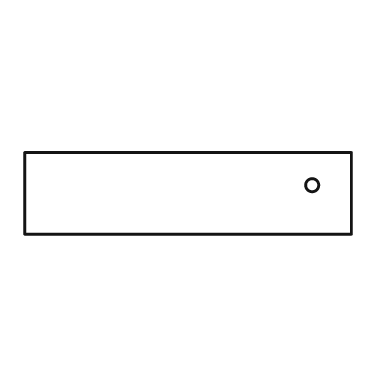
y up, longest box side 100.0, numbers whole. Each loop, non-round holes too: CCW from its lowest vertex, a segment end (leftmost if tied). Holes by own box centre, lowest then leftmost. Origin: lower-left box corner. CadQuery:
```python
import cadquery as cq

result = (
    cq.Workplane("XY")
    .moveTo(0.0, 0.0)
    .lineTo(100.0, 0.0)
    .lineTo(100.0, 25.0)
    .lineTo(0.0, 25.0)
    .close()
    .moveTo(88.0, 15.0)
    .circle(2.0)
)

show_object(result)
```